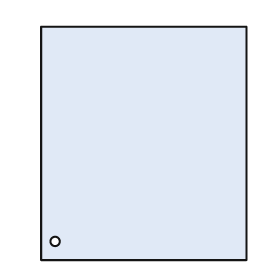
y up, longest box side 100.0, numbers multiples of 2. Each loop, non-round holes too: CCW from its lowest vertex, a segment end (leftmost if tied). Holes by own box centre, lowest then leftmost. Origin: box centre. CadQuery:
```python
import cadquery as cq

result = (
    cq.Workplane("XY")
    .moveTo(-44.0, -50.0)
    .lineTo(44.0, -50.0)
    .lineTo(44.0, 50.0)
    .lineTo(-44.0, 50.0)
    .close()
    .moveTo(-38.0, -42.0)
    .circle(2.0)
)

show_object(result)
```